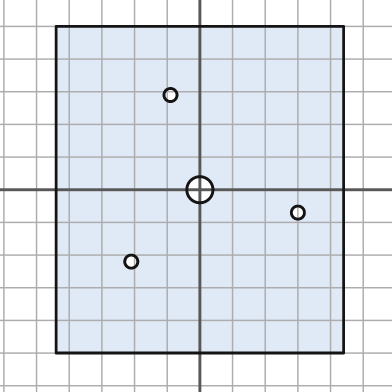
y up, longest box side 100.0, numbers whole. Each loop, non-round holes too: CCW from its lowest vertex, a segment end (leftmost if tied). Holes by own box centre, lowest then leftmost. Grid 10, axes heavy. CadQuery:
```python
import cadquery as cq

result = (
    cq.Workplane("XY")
    .moveTo(-44.0, -50.0)
    .lineTo(44.0, -50.0)
    .lineTo(44.0, 50.0)
    .lineTo(-44.0, 50.0)
    .close()
    .moveTo(-21.0, -22.0)
    .circle(2.0)
    .moveTo(30.0, -7.0)
    .circle(2.0)
    .moveTo(0.0, 0.0)
    .circle(4.0)
    .moveTo(-9.0, 29.0)
    .circle(2.0)
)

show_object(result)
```